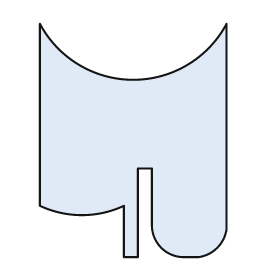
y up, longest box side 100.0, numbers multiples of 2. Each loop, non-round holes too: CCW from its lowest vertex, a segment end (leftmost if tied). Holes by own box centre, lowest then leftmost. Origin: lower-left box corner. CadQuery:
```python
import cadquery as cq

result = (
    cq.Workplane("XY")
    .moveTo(36.0, 0.0)
    .lineTo(42.0, 0.0)
    .lineTo(42.0, 38.0)
    .lineTo(48.0, 38.0)
    .lineTo(48.0, 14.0)
    .threePointArc((52.0, 4.0), (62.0, 0.0))
    .lineTo(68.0, 0.0)
    .threePointArc((76.0, 4.0), (80.0, 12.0))
    .lineTo(80.0, 100.0)
    .threePointArc((40.0, 76.0), (0.0, 100.0))
    .lineTo(0.0, 22.0)
    .threePointArc((18.0, 18.0), (36.0, 22.0))
    .close()
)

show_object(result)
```